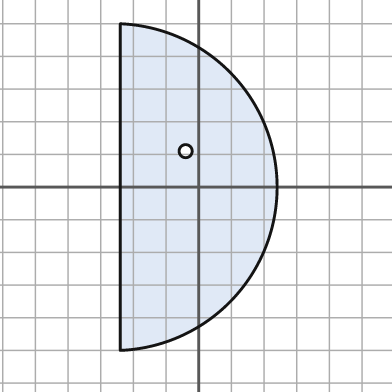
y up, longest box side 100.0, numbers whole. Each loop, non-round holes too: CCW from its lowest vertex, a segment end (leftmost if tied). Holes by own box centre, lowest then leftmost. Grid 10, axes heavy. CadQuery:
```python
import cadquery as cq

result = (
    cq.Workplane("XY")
    .moveTo(-24.0, -50.0)
    .threePointArc((24.0, 0.0), (-24.0, 50.0))
    .close()
    .moveTo(-4.0, 11.0)
    .circle(2.0)
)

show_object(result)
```